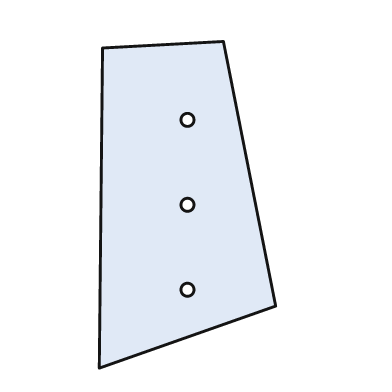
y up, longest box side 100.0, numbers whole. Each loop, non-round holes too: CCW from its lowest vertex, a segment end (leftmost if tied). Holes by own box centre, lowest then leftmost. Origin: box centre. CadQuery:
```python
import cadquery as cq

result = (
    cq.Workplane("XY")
    .moveTo(-27.0, -50.0)
    .lineTo(27.0, -31.0)
    .lineTo(11.0, 50.0)
    .lineTo(-26.0, 48.0)
    .close()
    .moveTo(0.0, -26.0)
    .circle(2.0)
    .moveTo(0.0, 0.0)
    .circle(2.0)
    .moveTo(0.0, 26.0)
    .circle(2.0)
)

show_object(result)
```